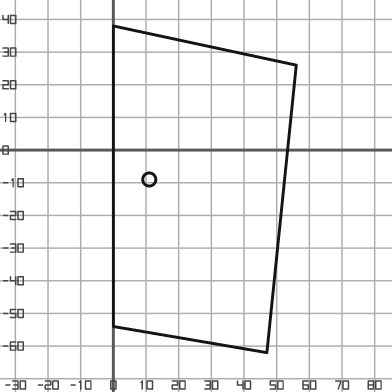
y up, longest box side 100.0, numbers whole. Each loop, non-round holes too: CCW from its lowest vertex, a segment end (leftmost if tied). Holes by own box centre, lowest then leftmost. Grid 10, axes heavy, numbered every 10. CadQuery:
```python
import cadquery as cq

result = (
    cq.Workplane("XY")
    .moveTo(47.0, -62.0)
    .lineTo(56.0, 26.0)
    .lineTo(0.0, 38.0)
    .lineTo(0.0, -54.0)
    .close()
    .moveTo(11.0, -9.0)
    .circle(2.0)
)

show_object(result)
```